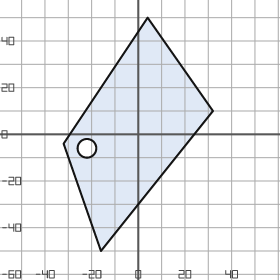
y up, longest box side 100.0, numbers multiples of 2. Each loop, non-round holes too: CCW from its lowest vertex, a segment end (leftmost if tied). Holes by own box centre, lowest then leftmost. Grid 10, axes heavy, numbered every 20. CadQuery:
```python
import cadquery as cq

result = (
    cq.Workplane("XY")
    .moveTo(-16.0, -50.0)
    .lineTo(32.0, 10.0)
    .lineTo(4.0, 50.0)
    .lineTo(-32.0, -4.0)
    .close()
    .moveTo(-22.0, -6.0)
    .circle(4.0)
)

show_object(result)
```